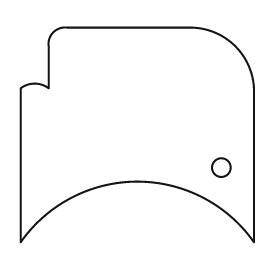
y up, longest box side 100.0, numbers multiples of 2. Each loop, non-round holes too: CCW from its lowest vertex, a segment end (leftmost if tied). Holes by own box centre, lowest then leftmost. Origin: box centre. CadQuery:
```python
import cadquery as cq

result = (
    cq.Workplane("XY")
    .moveTo(-50.0, -46.0)
    .threePointArc((0.0, -20.0), (50.0, -46.0))
    .lineTo(50.0, 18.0)
    .threePointArc((42.0, 38.0), (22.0, 46.0))
    .lineTo(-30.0, 46.0)
    .threePointArc((-36.0, 44.0), (-38.0, 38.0))
    .lineTo(-38.0, 20.0)
    .threePointArc((-44.0, 22.0), (-50.0, 20.0))
    .close()
    .moveTo(36.0, -14.0)
    .circle(4.0)
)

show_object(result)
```